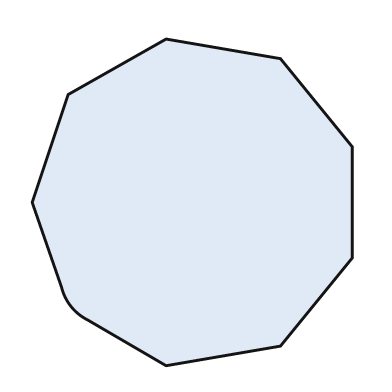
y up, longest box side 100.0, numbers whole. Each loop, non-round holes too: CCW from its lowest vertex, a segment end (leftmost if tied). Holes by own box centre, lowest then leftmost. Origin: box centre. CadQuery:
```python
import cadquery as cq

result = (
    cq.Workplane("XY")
    .moveTo(-8.0, -50.0)
    .lineTo(27.0, -44.0)
    .lineTo(49.0, -17.0)
    .lineTo(49.0, 17.0)
    .lineTo(27.0, 44.0)
    .lineTo(-8.0, 50.0)
    .lineTo(-38.0, 33.0)
    .lineTo(-49.0, 0.0)
    .lineTo(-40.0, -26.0)
    .threePointArc((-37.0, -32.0), (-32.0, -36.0))
    .close()
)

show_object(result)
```